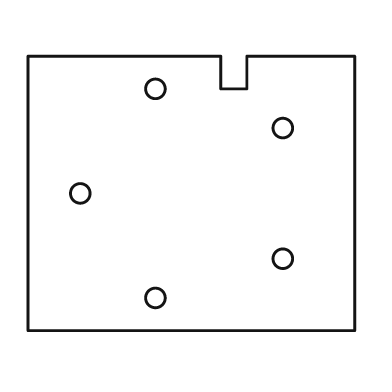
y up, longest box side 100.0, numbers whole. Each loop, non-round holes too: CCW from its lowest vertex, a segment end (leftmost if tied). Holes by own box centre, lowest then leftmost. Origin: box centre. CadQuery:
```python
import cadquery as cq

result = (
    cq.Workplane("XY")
    .moveTo(-50.0, -42.0)
    .lineTo(50.0, -42.0)
    .lineTo(50.0, 42.0)
    .lineTo(17.0, 42.0)
    .lineTo(17.0, 32.0)
    .lineTo(9.0, 32.0)
    .lineTo(9.0, 42.0)
    .lineTo(-50.0, 42.0)
    .close()
    .moveTo(-11.0, -32.0)
    .circle(3.0)
    .moveTo(28.0, -20.0)
    .circle(3.0)
    .moveTo(-34.0, 0.0)
    .circle(3.0)
    .moveTo(28.0, 20.0)
    .circle(3.0)
    .moveTo(-11.0, 32.0)
    .circle(3.0)
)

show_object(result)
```